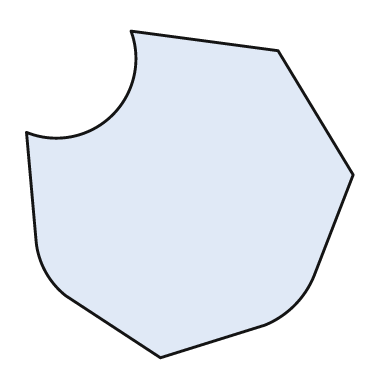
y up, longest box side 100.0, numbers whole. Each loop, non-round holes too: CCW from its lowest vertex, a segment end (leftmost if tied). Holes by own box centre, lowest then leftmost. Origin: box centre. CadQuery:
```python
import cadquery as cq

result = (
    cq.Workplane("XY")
    .moveTo(-9.0, -50.0)
    .lineTo(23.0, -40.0)
    .threePointArc((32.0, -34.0), (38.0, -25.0))
    .lineTo(50.0, 6.0)
    .lineTo(27.0, 44.0)
    .lineTo(-18.0, 50.0)
    .threePointArc((-24.0, 24.0), (-50.0, 19.0))
    .lineTo(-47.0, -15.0)
    .threePointArc((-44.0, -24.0), (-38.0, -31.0))
    .close()
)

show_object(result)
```